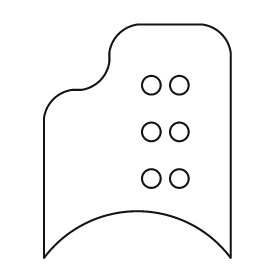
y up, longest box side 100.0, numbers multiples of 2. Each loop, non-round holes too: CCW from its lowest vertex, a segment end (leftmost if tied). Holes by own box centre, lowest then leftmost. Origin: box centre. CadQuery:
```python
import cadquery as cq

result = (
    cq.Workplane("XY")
    .moveTo(-40.0, -50.0)
    .threePointArc((0.0, -30.0), (40.0, -50.0))
    .lineTo(40.0, 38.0)
    .threePointArc((36.0, 46.0), (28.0, 50.0))
    .lineTo(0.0, 50.0)
    .threePointArc((-8.0, 46.0), (-12.0, 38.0))
    .lineTo(-12.0, 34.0)
    .threePointArc((-16.0, 26.0), (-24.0, 22.0))
    .lineTo(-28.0, 22.0)
    .threePointArc((-36.0, 18.0), (-40.0, 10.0))
    .close()
    .moveTo(6.0, -16.0)
    .circle(4.0)
    .moveTo(18.0, -16.0)
    .circle(4.0)
    .moveTo(6.0, 4.0)
    .circle(4.0)
    .moveTo(18.0, 4.0)
    .circle(4.0)
    .moveTo(6.0, 24.0)
    .circle(4.0)
    .moveTo(18.0, 24.0)
    .circle(4.0)
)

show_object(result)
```